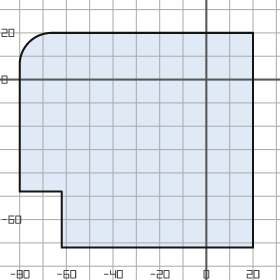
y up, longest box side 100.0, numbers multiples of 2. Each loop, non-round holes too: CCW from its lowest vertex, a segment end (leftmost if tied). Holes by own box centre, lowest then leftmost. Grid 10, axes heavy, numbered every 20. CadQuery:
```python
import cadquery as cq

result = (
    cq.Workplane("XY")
    .moveTo(-62.0, -72.0)
    .lineTo(20.0, -72.0)
    .lineTo(20.0, 20.0)
    .lineTo(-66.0, 20.0)
    .threePointArc((-76.0, 16.0), (-80.0, 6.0))
    .lineTo(-80.0, -48.0)
    .lineTo(-62.0, -48.0)
    .close()
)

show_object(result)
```